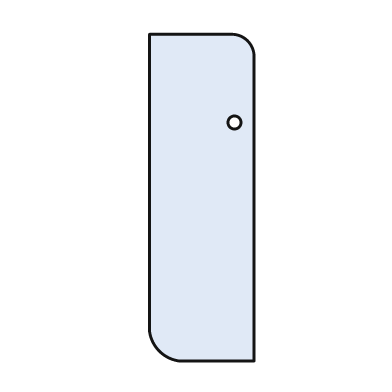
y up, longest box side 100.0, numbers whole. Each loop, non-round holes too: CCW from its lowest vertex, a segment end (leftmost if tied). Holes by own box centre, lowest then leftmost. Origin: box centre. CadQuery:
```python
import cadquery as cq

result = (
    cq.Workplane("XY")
    .moveTo(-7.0, -50.0)
    .lineTo(16.0, -50.0)
    .lineTo(16.0, 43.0)
    .threePointArc((14.0, 48.0), (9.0, 50.0))
    .lineTo(-16.0, 50.0)
    .lineTo(-16.0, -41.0)
    .threePointArc((-13.0, -47.0), (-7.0, -50.0))
    .close()
    .moveTo(10.0, 23.0)
    .circle(2.0)
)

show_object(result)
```